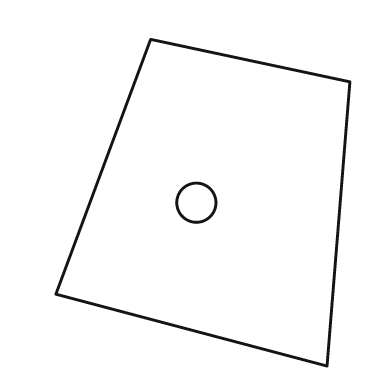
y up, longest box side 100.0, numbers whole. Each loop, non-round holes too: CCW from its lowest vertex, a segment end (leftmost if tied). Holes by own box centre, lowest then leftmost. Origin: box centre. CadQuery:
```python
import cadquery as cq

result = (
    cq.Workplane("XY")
    .moveTo(38.0, -50.0)
    .lineTo(45.0, 37.0)
    .lineTo(-16.0, 50.0)
    .lineTo(-45.0, -28.0)
    .close()
    .moveTo(-2.0, 0.0)
    .circle(6.0)
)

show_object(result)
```